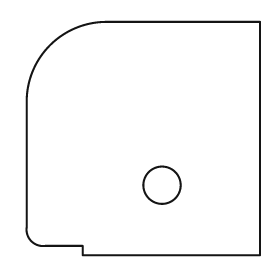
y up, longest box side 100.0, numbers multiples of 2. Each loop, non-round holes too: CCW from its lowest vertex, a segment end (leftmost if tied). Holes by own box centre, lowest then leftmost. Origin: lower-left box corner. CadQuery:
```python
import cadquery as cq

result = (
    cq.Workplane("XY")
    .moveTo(24.0, 0.0)
    .lineTo(100.0, 0.0)
    .lineTo(100.0, 100.0)
    .lineTo(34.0, 100.0)
    .threePointArc((10.0, 90.0), (0.0, 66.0))
    .lineTo(0.0, 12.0)
    .threePointArc((2.0, 6.0), (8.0, 4.0))
    .lineTo(24.0, 4.0)
    .close()
    .moveTo(58.0, 30.0)
    .circle(8.0)
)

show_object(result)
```